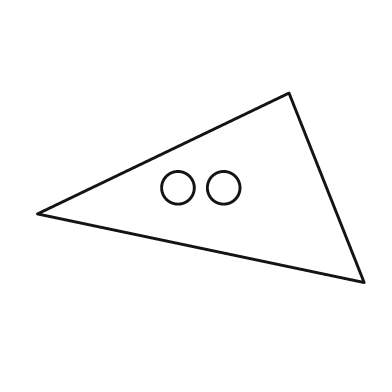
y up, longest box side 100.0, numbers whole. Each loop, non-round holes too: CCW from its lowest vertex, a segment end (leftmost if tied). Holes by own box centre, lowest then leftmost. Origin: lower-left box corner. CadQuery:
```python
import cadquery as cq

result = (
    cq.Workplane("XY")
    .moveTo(100.0, 0.0)
    .lineTo(77.0, 58.0)
    .lineTo(0.0, 21.0)
    .close()
    .moveTo(43.0, 29.0)
    .circle(5.0)
    .moveTo(57.0, 29.0)
    .circle(5.0)
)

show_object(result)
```